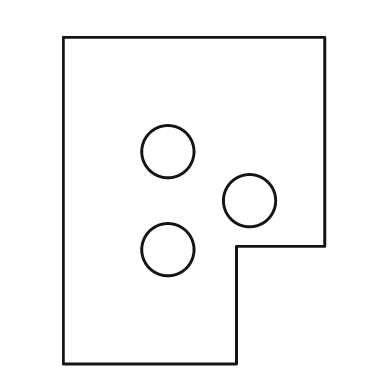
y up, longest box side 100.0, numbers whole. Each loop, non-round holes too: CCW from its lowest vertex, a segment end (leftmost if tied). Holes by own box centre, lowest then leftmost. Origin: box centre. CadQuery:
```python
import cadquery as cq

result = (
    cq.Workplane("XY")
    .moveTo(-40.0, -50.0)
    .lineTo(13.0, -50.0)
    .lineTo(13.0, -14.0)
    .lineTo(40.0, -14.0)
    .lineTo(40.0, 50.0)
    .lineTo(-40.0, 50.0)
    .close()
    .moveTo(-8.0, -15.0)
    .circle(8.0)
    .moveTo(17.0, 0.0)
    .circle(8.0)
    .moveTo(-8.0, 15.0)
    .circle(8.0)
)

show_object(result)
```